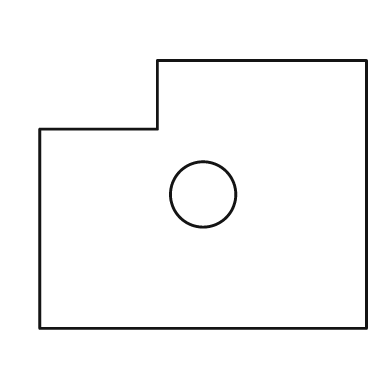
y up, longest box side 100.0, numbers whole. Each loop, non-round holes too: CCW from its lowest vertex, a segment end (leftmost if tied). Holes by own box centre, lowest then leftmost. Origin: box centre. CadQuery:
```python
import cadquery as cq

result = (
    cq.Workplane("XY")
    .moveTo(-50.0, -41.0)
    .lineTo(50.0, -41.0)
    .lineTo(50.0, 41.0)
    .lineTo(-14.0, 41.0)
    .lineTo(-14.0, 20.0)
    .lineTo(-50.0, 20.0)
    .close()
    .moveTo(0.0, 0.0)
    .circle(10.0)
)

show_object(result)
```